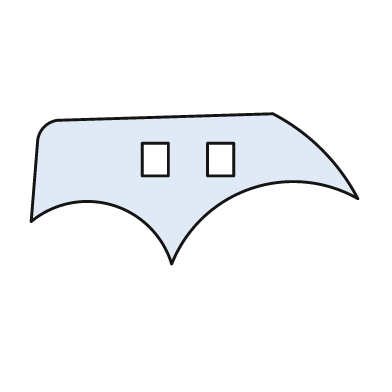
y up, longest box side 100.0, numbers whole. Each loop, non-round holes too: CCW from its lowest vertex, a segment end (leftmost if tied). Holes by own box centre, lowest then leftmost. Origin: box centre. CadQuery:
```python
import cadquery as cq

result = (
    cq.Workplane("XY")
    .moveTo(-7.0, -23.0)
    .threePointArc((17.0, 0.0), (50.0, -3.0))
    .threePointArc((39.0, 12.0), (24.0, 23.0))
    .lineTo(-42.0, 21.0)
    .threePointArc((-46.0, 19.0), (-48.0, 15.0))
    .lineTo(-50.0, -10.0)
    .threePointArc((-25.0, -5.0), (-7.0, -23.0))
    .close()
    .moveTo(-16.0, 4.0)
    .lineTo(-8.0, 4.0)
    .lineTo(-8.0, 14.0)
    .lineTo(-16.0, 14.0)
    .close()
    .moveTo(4.0, 4.0)
    .lineTo(12.0, 4.0)
    .lineTo(12.0, 14.0)
    .lineTo(4.0, 14.0)
    .close()
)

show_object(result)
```